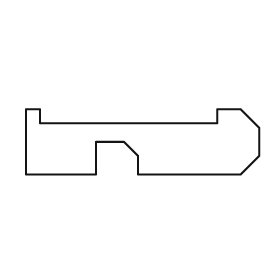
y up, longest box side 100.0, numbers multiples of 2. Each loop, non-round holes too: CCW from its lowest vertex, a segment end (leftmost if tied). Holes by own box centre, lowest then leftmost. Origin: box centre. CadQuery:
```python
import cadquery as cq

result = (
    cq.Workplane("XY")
    .moveTo(-50.0, -14.0)
    .lineTo(-20.0, -14.0)
    .lineTo(-20.0, 0.0)
    .lineTo(-8.0, 0.0)
    .lineTo(-2.0, -6.0)
    .lineTo(-2.0, -14.0)
    .lineTo(42.0, -14.0)
    .lineTo(50.0, -6.0)
    .lineTo(50.0, 6.0)
    .lineTo(42.0, 14.0)
    .lineTo(32.0, 14.0)
    .lineTo(32.0, 8.0)
    .lineTo(-44.0, 8.0)
    .lineTo(-44.0, 14.0)
    .lineTo(-50.0, 14.0)
    .close()
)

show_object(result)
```